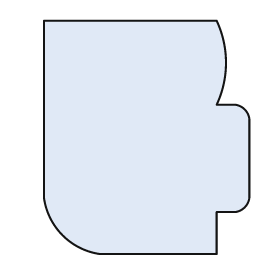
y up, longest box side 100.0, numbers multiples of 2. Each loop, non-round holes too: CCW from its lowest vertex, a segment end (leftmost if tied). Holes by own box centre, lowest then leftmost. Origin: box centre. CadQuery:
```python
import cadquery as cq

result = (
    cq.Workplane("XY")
    .moveTo(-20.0, -50.0)
    .lineTo(30.0, -50.0)
    .lineTo(30.0, -32.0)
    .lineTo(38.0, -32.0)
    .threePointArc((42.0, -30.0), (44.0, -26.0))
    .lineTo(44.0, 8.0)
    .threePointArc((42.0, 12.0), (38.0, 14.0))
    .lineTo(30.0, 14.0)
    .threePointArc((34.0, 32.0), (30.0, 50.0))
    .lineTo(-44.0, 50.0)
    .lineTo(-44.0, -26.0)
    .threePointArc((-36.0, -42.0), (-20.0, -50.0))
    .close()
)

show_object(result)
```